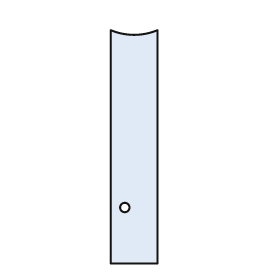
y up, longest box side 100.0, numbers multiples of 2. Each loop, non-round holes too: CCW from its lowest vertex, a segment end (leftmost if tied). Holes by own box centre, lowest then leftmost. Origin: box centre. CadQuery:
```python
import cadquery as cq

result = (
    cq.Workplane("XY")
    .moveTo(-10.0, -50.0)
    .lineTo(10.0, -50.0)
    .lineTo(10.0, 50.0)
    .threePointArc((0.0, 48.0), (-10.0, 50.0))
    .close()
    .moveTo(-4.0, -26.0)
    .circle(2.0)
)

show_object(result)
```